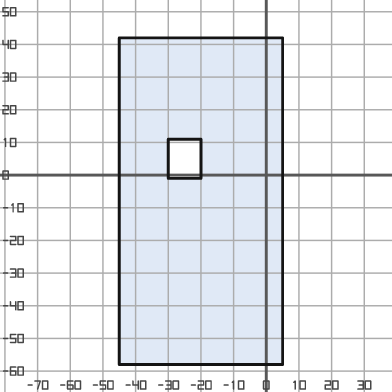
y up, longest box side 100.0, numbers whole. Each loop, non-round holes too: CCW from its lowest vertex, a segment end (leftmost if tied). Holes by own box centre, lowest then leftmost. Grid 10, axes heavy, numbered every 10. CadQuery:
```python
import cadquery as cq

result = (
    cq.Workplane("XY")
    .moveTo(-45.0, -58.0)
    .lineTo(5.0, -58.0)
    .lineTo(5.0, 42.0)
    .lineTo(-45.0, 42.0)
    .close()
    .moveTo(-30.0, -1.0)
    .lineTo(-20.0, -1.0)
    .lineTo(-20.0, 11.0)
    .lineTo(-30.0, 11.0)
    .close()
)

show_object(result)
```